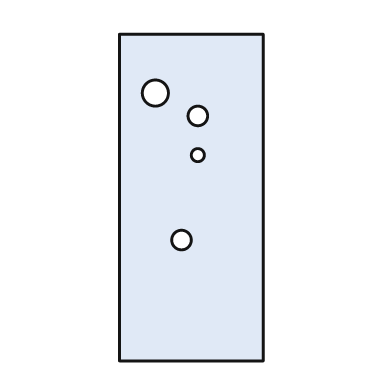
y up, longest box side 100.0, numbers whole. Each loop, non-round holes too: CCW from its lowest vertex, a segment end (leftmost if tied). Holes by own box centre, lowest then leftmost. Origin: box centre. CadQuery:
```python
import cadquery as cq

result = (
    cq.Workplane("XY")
    .moveTo(-22.0, -50.0)
    .lineTo(22.0, -50.0)
    .lineTo(22.0, 50.0)
    .lineTo(-22.0, 50.0)
    .close()
    .moveTo(-3.0, -13.0)
    .circle(3.0)
    .moveTo(2.0, 13.0)
    .circle(2.0)
    .moveTo(2.0, 25.0)
    .circle(3.0)
    .moveTo(-11.0, 32.0)
    .circle(4.0)
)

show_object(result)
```